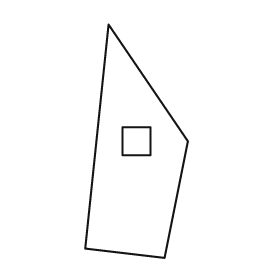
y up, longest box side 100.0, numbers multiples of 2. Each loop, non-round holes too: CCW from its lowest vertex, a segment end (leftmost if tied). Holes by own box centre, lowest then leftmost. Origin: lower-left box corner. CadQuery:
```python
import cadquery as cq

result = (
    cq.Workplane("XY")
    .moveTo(34.0, 0.0)
    .lineTo(44.0, 50.0)
    .lineTo(10.0, 100.0)
    .lineTo(0.0, 4.0)
    .close()
    .moveTo(16.0, 44.0)
    .lineTo(28.0, 44.0)
    .lineTo(28.0, 56.0)
    .lineTo(16.0, 56.0)
    .close()
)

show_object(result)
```